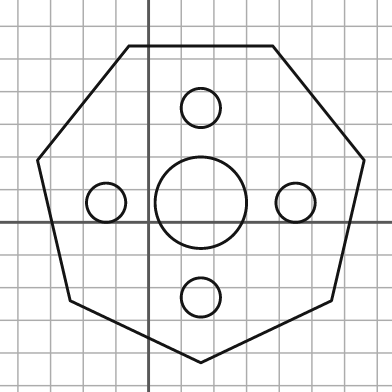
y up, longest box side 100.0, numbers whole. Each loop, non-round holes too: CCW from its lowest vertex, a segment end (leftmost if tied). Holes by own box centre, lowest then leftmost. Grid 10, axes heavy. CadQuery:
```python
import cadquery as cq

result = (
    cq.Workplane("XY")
    .moveTo(16.0, -43.0)
    .lineTo(56.0, -24.0)
    .lineTo(66.0, 19.0)
    .lineTo(38.0, 54.0)
    .lineTo(-6.0, 54.0)
    .lineTo(-34.0, 19.0)
    .lineTo(-24.0, -24.0)
    .close()
    .moveTo(16.0, -23.0)
    .circle(6.0)
    .moveTo(-13.0, 6.0)
    .circle(6.0)
    .moveTo(16.0, 6.0)
    .circle(14.0)
    .moveTo(45.0, 6.0)
    .circle(6.0)
    .moveTo(16.0, 35.0)
    .circle(6.0)
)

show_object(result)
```